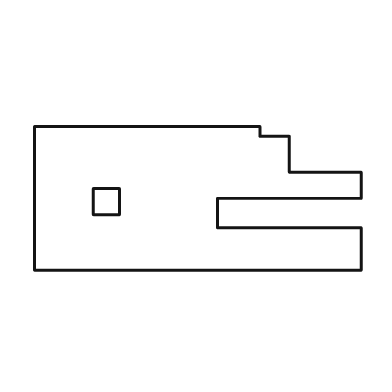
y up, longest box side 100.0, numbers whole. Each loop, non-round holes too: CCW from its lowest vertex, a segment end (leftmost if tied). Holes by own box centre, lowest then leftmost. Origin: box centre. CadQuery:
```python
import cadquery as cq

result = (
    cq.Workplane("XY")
    .moveTo(-50.0, -22.0)
    .lineTo(50.0, -22.0)
    .lineTo(50.0, -9.0)
    .lineTo(6.0, -9.0)
    .lineTo(6.0, 0.0)
    .lineTo(50.0, 0.0)
    .lineTo(50.0, 8.0)
    .lineTo(28.0, 8.0)
    .lineTo(28.0, 19.0)
    .lineTo(19.0, 19.0)
    .lineTo(19.0, 22.0)
    .lineTo(-50.0, 22.0)
    .close()
    .moveTo(-32.0, -5.0)
    .lineTo(-24.0, -5.0)
    .lineTo(-24.0, 3.0)
    .lineTo(-32.0, 3.0)
    .close()
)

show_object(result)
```